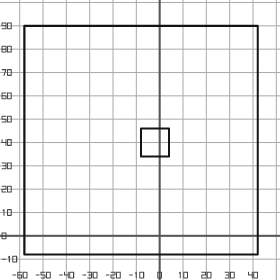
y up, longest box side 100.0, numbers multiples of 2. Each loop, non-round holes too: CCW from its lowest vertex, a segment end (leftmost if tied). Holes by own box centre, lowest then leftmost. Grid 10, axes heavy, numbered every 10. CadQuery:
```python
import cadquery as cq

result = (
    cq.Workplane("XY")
    .moveTo(-58.0, -8.0)
    .lineTo(42.0, -8.0)
    .lineTo(42.0, 90.0)
    .lineTo(-58.0, 90.0)
    .close()
    .moveTo(-8.0, 34.0)
    .lineTo(4.0, 34.0)
    .lineTo(4.0, 46.0)
    .lineTo(-8.0, 46.0)
    .close()
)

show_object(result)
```